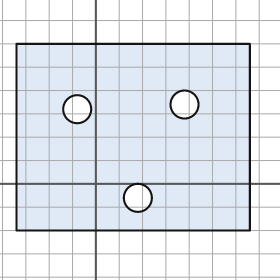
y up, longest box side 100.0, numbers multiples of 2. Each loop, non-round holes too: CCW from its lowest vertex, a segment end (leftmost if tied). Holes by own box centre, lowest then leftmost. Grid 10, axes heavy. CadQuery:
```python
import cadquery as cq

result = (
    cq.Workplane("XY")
    .moveTo(-34.0, -20.0)
    .lineTo(66.0, -20.0)
    .lineTo(66.0, 60.0)
    .lineTo(-34.0, 60.0)
    .close()
    .moveTo(18.0, -6.0)
    .circle(6.0)
    .moveTo(-8.0, 32.0)
    .circle(6.0)
    .moveTo(38.0, 34.0)
    .circle(6.0)
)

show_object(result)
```